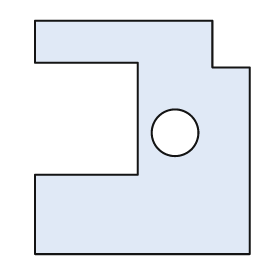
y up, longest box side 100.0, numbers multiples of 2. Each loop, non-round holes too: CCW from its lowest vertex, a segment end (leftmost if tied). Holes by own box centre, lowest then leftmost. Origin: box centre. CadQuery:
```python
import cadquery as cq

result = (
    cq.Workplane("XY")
    .moveTo(-46.0, -50.0)
    .lineTo(46.0, -50.0)
    .lineTo(46.0, 30.0)
    .lineTo(30.0, 30.0)
    .lineTo(30.0, 50.0)
    .lineTo(-46.0, 50.0)
    .lineTo(-46.0, 32.0)
    .lineTo(-2.0, 32.0)
    .lineTo(-2.0, -16.0)
    .lineTo(-46.0, -16.0)
    .close()
    .moveTo(14.0, 2.0)
    .circle(10.0)
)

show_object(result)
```